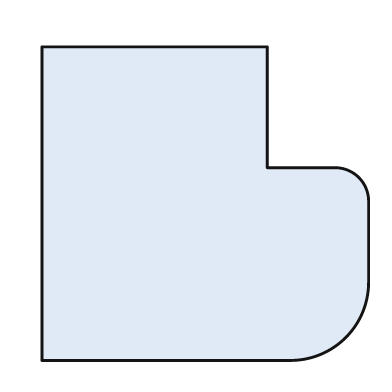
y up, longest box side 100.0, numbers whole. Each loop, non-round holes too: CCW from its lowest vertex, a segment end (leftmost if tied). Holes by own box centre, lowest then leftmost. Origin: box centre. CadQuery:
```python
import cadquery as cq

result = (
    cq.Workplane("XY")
    .moveTo(-50.0, -48.0)
    .lineTo(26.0, -48.0)
    .threePointArc((43.0, -41.0), (50.0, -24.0))
    .lineTo(50.0, 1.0)
    .threePointArc((47.0, 8.0), (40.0, 11.0))
    .lineTo(19.0, 11.0)
    .lineTo(19.0, 48.0)
    .lineTo(-50.0, 48.0)
    .close()
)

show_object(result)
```